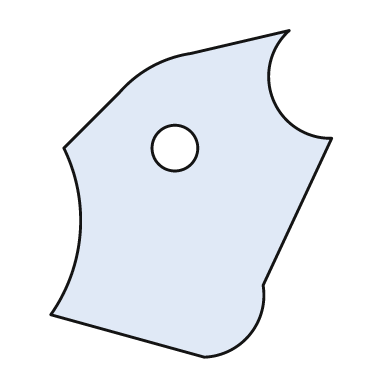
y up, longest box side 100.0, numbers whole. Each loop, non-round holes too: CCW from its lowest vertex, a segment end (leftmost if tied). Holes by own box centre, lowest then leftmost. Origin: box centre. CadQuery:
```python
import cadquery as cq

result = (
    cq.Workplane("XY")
    .moveTo(4.0, -50.0)
    .threePointArc((18.0, -43.0), (22.0, -28.0))
    .lineTo(43.0, 17.0)
    .threePointArc((25.0, 29.0), (30.0, 50.0))
    .lineTo(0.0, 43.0)
    .threePointArc((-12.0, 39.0), (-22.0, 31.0))
    .lineTo(-39.0, 14.0)
    .threePointArc((-34.0, -12.0), (-43.0, -37.0))
    .close()
    .moveTo(-5.0, 14.0)
    .circle(7.0)
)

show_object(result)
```